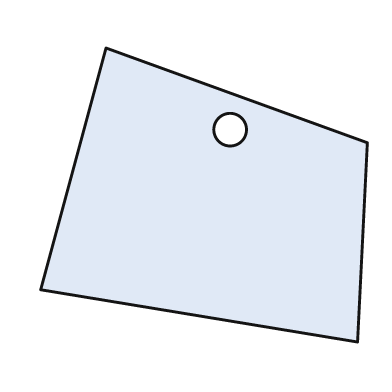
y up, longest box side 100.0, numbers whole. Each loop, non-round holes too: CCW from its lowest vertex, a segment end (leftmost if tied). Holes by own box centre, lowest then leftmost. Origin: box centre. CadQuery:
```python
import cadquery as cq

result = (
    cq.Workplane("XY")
    .moveTo(47.0, -45.0)
    .lineTo(50.0, 16.0)
    .lineTo(-30.0, 45.0)
    .lineTo(-50.0, -29.0)
    .close()
    .moveTo(8.0, 20.0)
    .circle(5.0)
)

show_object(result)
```